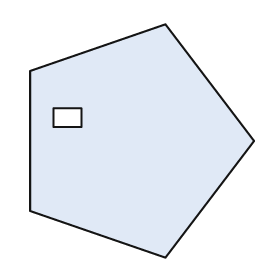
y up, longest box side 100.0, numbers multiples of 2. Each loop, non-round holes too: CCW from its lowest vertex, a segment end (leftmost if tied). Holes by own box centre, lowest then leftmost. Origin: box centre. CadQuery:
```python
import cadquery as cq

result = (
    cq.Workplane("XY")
    .moveTo(10.0, -50.0)
    .lineTo(48.0, 0.0)
    .lineTo(10.0, 50.0)
    .lineTo(-48.0, 30.0)
    .lineTo(-48.0, -30.0)
    .close()
    .moveTo(-38.0, 6.0)
    .lineTo(-26.0, 6.0)
    .lineTo(-26.0, 14.0)
    .lineTo(-38.0, 14.0)
    .close()
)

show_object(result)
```